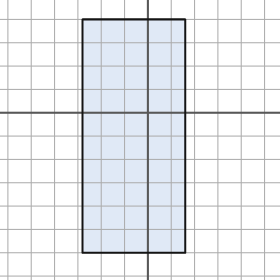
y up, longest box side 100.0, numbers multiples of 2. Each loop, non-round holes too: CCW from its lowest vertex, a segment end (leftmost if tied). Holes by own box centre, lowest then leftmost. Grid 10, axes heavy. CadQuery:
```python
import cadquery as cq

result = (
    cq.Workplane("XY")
    .moveTo(-28.0, -60.0)
    .lineTo(16.0, -60.0)
    .lineTo(16.0, 40.0)
    .lineTo(-28.0, 40.0)
    .close()
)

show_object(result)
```